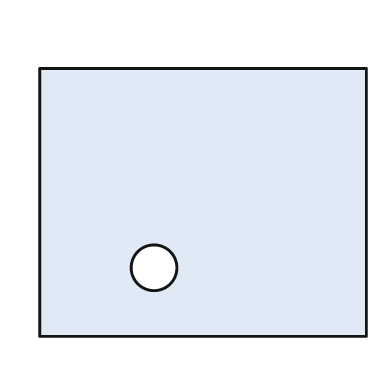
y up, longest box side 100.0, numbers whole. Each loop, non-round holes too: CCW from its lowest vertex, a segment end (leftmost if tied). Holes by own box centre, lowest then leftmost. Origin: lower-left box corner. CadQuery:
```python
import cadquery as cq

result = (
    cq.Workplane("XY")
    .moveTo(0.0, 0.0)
    .lineTo(100.0, 0.0)
    .lineTo(100.0, 82.0)
    .lineTo(0.0, 82.0)
    .close()
    .moveTo(35.0, 21.0)
    .circle(7.0)
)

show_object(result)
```